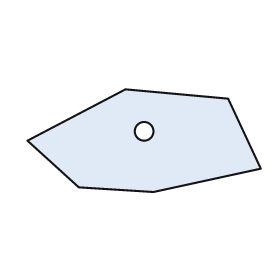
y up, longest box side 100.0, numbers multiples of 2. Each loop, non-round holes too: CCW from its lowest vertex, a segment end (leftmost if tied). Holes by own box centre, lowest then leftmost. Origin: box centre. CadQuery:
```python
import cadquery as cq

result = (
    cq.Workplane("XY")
    .moveTo(4.0, -22.0)
    .lineTo(50.0, -12.0)
    .lineTo(36.0, 18.0)
    .lineTo(-8.0, 22.0)
    .lineTo(-50.0, 0.0)
    .lineTo(-28.0, -20.0)
    .close()
    .moveTo(0.0, 4.0)
    .circle(4.0)
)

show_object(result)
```